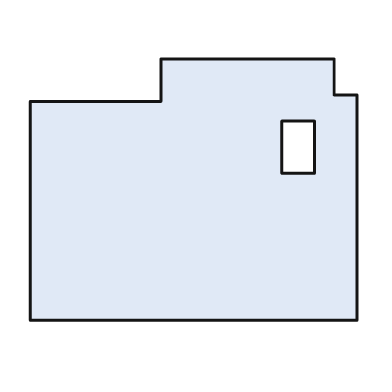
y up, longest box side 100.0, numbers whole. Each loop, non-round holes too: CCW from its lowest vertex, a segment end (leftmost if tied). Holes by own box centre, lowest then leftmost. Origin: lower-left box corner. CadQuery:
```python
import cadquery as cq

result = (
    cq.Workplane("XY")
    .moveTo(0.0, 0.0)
    .lineTo(100.0, 0.0)
    .lineTo(100.0, 69.0)
    .lineTo(93.0, 69.0)
    .lineTo(93.0, 80.0)
    .lineTo(40.0, 80.0)
    .lineTo(40.0, 67.0)
    .lineTo(0.0, 67.0)
    .close()
    .moveTo(77.0, 45.0)
    .lineTo(87.0, 45.0)
    .lineTo(87.0, 61.0)
    .lineTo(77.0, 61.0)
    .close()
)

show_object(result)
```